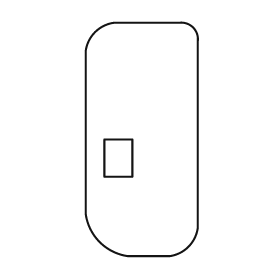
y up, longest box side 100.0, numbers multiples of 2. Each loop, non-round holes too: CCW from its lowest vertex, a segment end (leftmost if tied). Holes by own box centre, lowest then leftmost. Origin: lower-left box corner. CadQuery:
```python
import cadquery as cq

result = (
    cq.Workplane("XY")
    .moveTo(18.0, 0.0)
    .lineTo(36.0, 0.0)
    .threePointArc((44.0, 4.0), (48.0, 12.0))
    .lineTo(48.0, 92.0)
    .threePointArc((46.0, 98.0), (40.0, 100.0))
    .lineTo(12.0, 100.0)
    .threePointArc((4.0, 96.0), (0.0, 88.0))
    .lineTo(0.0, 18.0)
    .threePointArc((6.0, 6.0), (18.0, 0.0))
    .close()
    .moveTo(8.0, 34.0)
    .lineTo(20.0, 34.0)
    .lineTo(20.0, 50.0)
    .lineTo(8.0, 50.0)
    .close()
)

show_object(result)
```